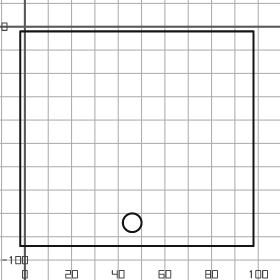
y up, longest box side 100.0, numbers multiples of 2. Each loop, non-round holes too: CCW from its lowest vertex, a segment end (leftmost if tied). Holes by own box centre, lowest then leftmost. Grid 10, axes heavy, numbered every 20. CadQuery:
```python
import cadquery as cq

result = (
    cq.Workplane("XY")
    .moveTo(-2.0, -94.0)
    .lineTo(98.0, -94.0)
    .lineTo(98.0, -2.0)
    .lineTo(-2.0, -2.0)
    .close()
    .moveTo(46.0, -84.0)
    .circle(4.0)
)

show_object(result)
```